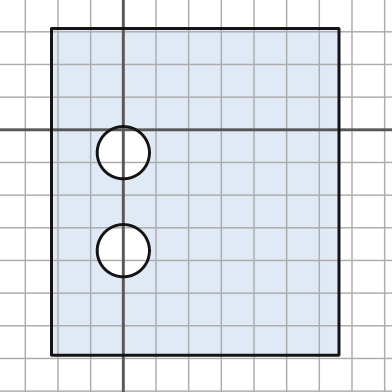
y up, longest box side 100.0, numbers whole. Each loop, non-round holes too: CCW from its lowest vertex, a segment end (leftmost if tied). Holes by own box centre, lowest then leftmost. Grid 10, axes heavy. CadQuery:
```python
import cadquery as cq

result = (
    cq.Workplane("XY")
    .moveTo(-22.0, -69.0)
    .lineTo(66.0, -69.0)
    .lineTo(66.0, 31.0)
    .lineTo(-22.0, 31.0)
    .close()
    .moveTo(0.0, -37.0)
    .circle(8.0)
    .moveTo(0.0, -7.0)
    .circle(8.0)
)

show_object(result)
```